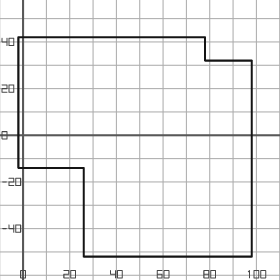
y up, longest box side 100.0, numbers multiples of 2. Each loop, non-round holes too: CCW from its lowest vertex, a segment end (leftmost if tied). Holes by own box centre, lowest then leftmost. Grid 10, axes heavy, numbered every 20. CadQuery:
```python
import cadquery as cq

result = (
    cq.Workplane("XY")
    .moveTo(26.0, -52.0)
    .lineTo(98.0, -52.0)
    .lineTo(98.0, 32.0)
    .lineTo(78.0, 32.0)
    .lineTo(78.0, 42.0)
    .lineTo(-2.0, 42.0)
    .lineTo(-2.0, -14.0)
    .lineTo(26.0, -14.0)
    .close()
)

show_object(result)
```